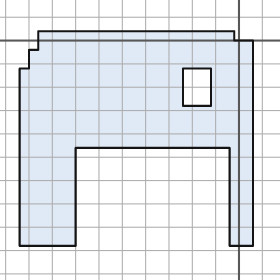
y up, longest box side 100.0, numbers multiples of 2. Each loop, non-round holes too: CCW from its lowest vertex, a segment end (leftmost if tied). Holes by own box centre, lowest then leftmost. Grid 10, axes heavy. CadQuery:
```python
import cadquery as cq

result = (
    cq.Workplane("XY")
    .moveTo(-94.0, -88.0)
    .lineTo(-70.0, -88.0)
    .lineTo(-70.0, -46.0)
    .lineTo(-4.0, -46.0)
    .lineTo(-4.0, -88.0)
    .lineTo(6.0, -88.0)
    .lineTo(6.0, 0.0)
    .lineTo(-2.0, 0.0)
    .lineTo(-2.0, 4.0)
    .lineTo(-86.0, 4.0)
    .lineTo(-86.0, -4.0)
    .lineTo(-90.0, -4.0)
    .lineTo(-90.0, -12.0)
    .lineTo(-94.0, -12.0)
    .close()
    .moveTo(-24.0, -28.0)
    .lineTo(-12.0, -28.0)
    .lineTo(-12.0, -12.0)
    .lineTo(-24.0, -12.0)
    .close()
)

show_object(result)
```